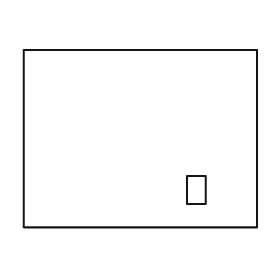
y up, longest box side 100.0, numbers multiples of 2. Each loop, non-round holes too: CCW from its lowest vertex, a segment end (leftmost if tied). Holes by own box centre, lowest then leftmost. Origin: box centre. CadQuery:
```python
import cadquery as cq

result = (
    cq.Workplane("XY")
    .moveTo(-50.0, -38.0)
    .lineTo(50.0, -38.0)
    .lineTo(50.0, 38.0)
    .lineTo(-50.0, 38.0)
    .close()
    .moveTo(20.0, -28.0)
    .lineTo(28.0, -28.0)
    .lineTo(28.0, -16.0)
    .lineTo(20.0, -16.0)
    .close()
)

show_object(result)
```